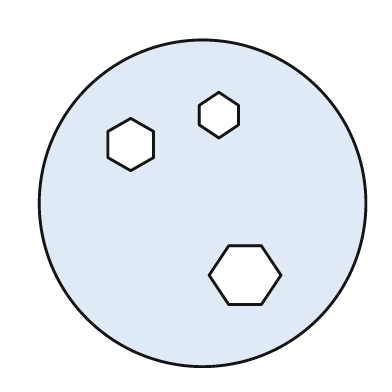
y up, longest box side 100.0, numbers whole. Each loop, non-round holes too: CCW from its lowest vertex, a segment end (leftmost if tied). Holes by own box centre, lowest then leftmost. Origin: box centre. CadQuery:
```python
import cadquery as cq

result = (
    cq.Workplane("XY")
    .moveTo(0.0, 0.0)
    .circle(50.0)
    .moveTo(8.0, -31.0)
    .lineTo(18.0, -31.0)
    .lineTo(24.0, -22.0)
    .lineTo(18.0, -13.0)
    .lineTo(8.0, -13.0)
    .lineTo(2.0, -22.0)
    .close()
    .moveTo(-22.0, 10.0)
    .lineTo(-15.0, 14.0)
    .lineTo(-15.0, 22.0)
    .lineTo(-22.0, 26.0)
    .lineTo(-29.0, 22.0)
    .lineTo(-29.0, 14.0)
    .close()
    .moveTo(5.0, 20.0)
    .lineTo(11.0, 24.0)
    .lineTo(11.0, 30.0)
    .lineTo(5.0, 34.0)
    .lineTo(-1.0, 30.0)
    .lineTo(-1.0, 24.0)
    .close()
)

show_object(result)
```